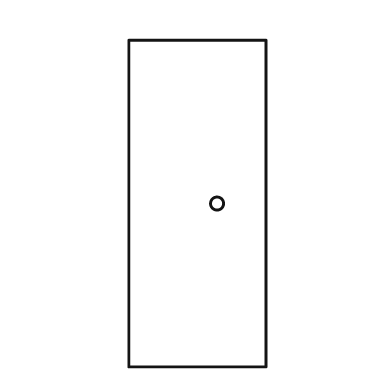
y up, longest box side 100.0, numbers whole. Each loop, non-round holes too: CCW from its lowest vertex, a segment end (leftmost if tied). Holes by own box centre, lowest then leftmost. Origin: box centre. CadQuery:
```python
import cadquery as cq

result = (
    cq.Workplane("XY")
    .moveTo(-21.0, -50.0)
    .lineTo(21.0, -50.0)
    .lineTo(21.0, 50.0)
    .lineTo(-21.0, 50.0)
    .close()
    .moveTo(6.0, 0.0)
    .circle(2.0)
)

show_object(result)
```